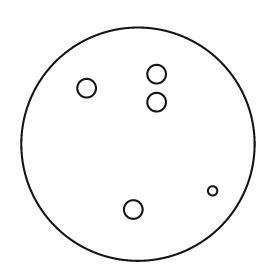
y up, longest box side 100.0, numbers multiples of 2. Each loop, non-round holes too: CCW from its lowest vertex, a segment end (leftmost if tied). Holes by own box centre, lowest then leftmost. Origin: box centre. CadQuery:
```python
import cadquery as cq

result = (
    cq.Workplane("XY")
    .moveTo(0.0, 0.0)
    .circle(50.0)
    .moveTo(-2.0, -28.0)
    .circle(4.0)
    .moveTo(32.0, -20.0)
    .circle(2.0)
    .moveTo(8.0, 18.0)
    .circle(4.0)
    .moveTo(-22.0, 24.0)
    .circle(4.0)
    .moveTo(8.0, 30.0)
    .circle(4.0)
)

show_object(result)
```